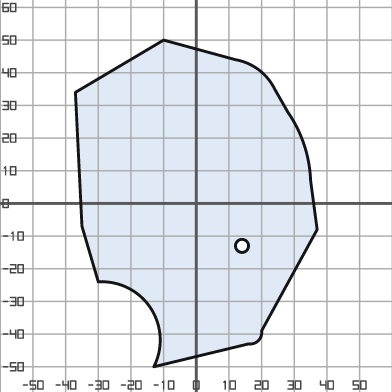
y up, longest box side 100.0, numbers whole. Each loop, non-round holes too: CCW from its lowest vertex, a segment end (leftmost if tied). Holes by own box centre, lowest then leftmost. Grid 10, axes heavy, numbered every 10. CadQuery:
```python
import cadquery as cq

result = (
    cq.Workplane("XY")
    .moveTo(-13.0, -50.0)
    .lineTo(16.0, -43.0)
    .threePointArc((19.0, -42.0), (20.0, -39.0))
    .lineTo(37.0, -8.0)
    .lineTo(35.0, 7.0)
    .threePointArc((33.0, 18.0), (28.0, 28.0))
    .lineTo(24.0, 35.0)
    .threePointArc((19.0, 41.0), (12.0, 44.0))
    .lineTo(-10.0, 50.0)
    .lineTo(-37.0, 34.0)
    .lineTo(-35.0, -7.0)
    .lineTo(-30.0, -24.0)
    .threePointArc((-14.0, -32.0), (-13.0, -50.0))
    .close()
    .moveTo(14.0, -13.0)
    .circle(2.0)
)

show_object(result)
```